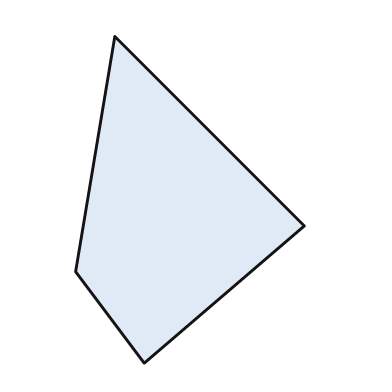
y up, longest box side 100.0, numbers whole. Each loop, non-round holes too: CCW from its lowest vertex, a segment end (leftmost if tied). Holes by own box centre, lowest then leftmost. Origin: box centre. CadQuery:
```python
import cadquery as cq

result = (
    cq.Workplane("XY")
    .moveTo(-14.0, -50.0)
    .lineTo(35.0, -8.0)
    .lineTo(-23.0, 50.0)
    .lineTo(-35.0, -22.0)
    .close()
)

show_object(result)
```